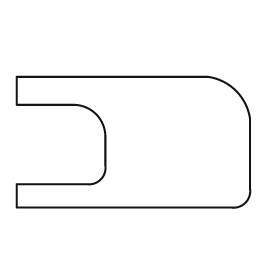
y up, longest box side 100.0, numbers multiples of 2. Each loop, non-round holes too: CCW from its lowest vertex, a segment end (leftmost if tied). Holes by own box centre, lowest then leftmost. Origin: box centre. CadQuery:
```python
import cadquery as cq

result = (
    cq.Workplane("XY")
    .moveTo(-50.0, -28.0)
    .lineTo(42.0, -28.0)
    .threePointArc((48.0, -26.0), (50.0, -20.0))
    .lineTo(50.0, 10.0)
    .threePointArc((44.0, 22.0), (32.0, 28.0))
    .lineTo(-50.0, 28.0)
    .lineTo(-50.0, 16.0)
    .lineTo(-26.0, 16.0)
    .threePointArc((-16.0, 12.0), (-12.0, 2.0))
    .lineTo(-12.0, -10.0)
    .threePointArc((-14.0, -16.0), (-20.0, -18.0))
    .lineTo(-50.0, -18.0)
    .close()
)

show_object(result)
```